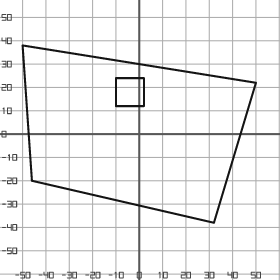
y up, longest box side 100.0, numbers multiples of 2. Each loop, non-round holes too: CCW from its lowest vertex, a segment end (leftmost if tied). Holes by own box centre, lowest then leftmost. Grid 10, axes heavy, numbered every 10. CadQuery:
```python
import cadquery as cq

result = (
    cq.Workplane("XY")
    .moveTo(32.0, -38.0)
    .lineTo(50.0, 22.0)
    .lineTo(-50.0, 38.0)
    .lineTo(-46.0, -20.0)
    .close()
    .moveTo(-10.0, 12.0)
    .lineTo(2.0, 12.0)
    .lineTo(2.0, 24.0)
    .lineTo(-10.0, 24.0)
    .close()
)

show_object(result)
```